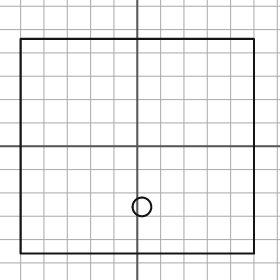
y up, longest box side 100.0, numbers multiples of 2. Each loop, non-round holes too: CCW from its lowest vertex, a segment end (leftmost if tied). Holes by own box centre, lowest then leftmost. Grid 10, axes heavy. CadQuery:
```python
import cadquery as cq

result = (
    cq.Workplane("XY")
    .moveTo(-50.0, -46.0)
    .lineTo(50.0, -46.0)
    .lineTo(50.0, 46.0)
    .lineTo(-50.0, 46.0)
    .close()
    .moveTo(2.0, -26.0)
    .circle(4.0)
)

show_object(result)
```